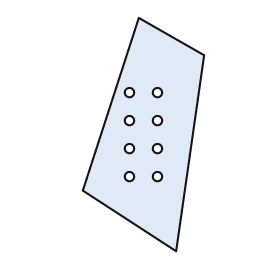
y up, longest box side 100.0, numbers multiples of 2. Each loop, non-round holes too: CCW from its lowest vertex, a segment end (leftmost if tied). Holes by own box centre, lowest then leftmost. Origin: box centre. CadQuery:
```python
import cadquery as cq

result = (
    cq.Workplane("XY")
    .moveTo(14.0, -50.0)
    .lineTo(26.0, 34.0)
    .lineTo(-2.0, 50.0)
    .lineTo(-26.0, -24.0)
    .close()
    .moveTo(-6.0, -18.0)
    .circle(2.0)
    .moveTo(6.0, -18.0)
    .circle(2.0)
    .moveTo(-6.0, -6.0)
    .circle(2.0)
    .moveTo(6.0, -6.0)
    .circle(2.0)
    .moveTo(-6.0, 6.0)
    .circle(2.0)
    .moveTo(6.0, 6.0)
    .circle(2.0)
    .moveTo(-6.0, 18.0)
    .circle(2.0)
    .moveTo(6.0, 18.0)
    .circle(2.0)
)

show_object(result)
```